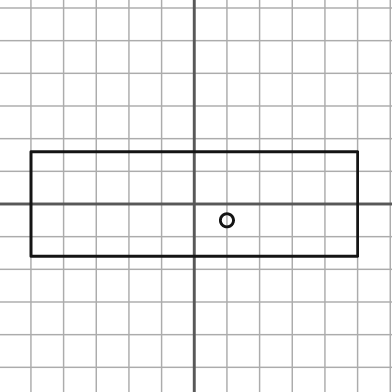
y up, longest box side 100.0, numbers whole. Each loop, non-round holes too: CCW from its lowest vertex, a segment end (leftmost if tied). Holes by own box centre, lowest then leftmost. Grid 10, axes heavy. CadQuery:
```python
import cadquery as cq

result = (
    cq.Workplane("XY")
    .moveTo(-50.0, -16.0)
    .lineTo(50.0, -16.0)
    .lineTo(50.0, 16.0)
    .lineTo(-50.0, 16.0)
    .close()
    .moveTo(10.0, -5.0)
    .circle(2.0)
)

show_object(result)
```